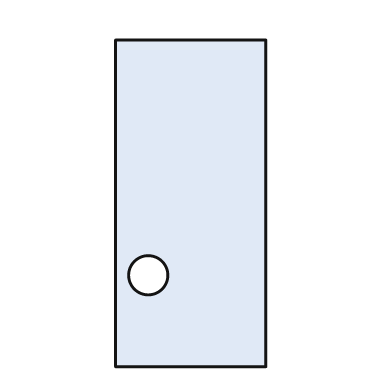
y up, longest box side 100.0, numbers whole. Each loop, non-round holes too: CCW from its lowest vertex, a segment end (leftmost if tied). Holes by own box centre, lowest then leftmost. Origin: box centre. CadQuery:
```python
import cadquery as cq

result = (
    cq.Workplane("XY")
    .moveTo(-23.0, -50.0)
    .lineTo(23.0, -50.0)
    .lineTo(23.0, 50.0)
    .lineTo(-23.0, 50.0)
    .close()
    .moveTo(-13.0, -22.0)
    .circle(6.0)
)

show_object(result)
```